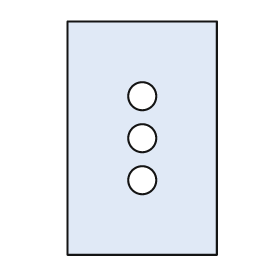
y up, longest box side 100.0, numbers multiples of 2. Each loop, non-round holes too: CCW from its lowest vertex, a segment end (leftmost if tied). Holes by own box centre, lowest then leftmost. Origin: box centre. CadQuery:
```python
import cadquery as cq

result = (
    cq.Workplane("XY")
    .moveTo(-32.0, -50.0)
    .lineTo(32.0, -50.0)
    .lineTo(32.0, 50.0)
    .lineTo(-32.0, 50.0)
    .close()
    .moveTo(0.0, -18.0)
    .circle(6.0)
    .moveTo(0.0, 0.0)
    .circle(6.0)
    .moveTo(0.0, 18.0)
    .circle(6.0)
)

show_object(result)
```